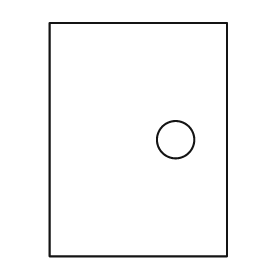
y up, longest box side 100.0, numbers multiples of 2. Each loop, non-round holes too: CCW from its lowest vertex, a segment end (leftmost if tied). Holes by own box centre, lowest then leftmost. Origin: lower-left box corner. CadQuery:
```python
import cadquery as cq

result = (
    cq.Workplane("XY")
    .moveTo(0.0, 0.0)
    .lineTo(76.0, 0.0)
    .lineTo(76.0, 100.0)
    .lineTo(0.0, 100.0)
    .close()
    .moveTo(54.0, 50.0)
    .circle(8.0)
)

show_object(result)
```